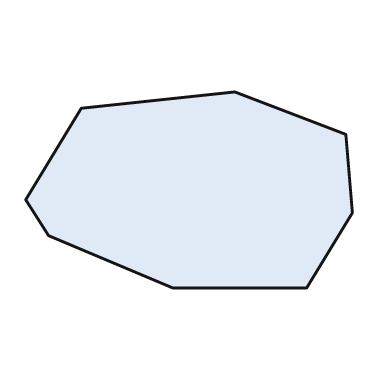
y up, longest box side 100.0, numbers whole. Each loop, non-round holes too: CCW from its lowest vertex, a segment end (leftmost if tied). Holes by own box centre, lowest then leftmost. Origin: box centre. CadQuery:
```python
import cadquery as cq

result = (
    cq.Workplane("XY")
    .moveTo(-5.0, -30.0)
    .lineTo(36.0, -30.0)
    .lineTo(50.0, -7.0)
    .lineTo(48.0, 17.0)
    .lineTo(14.0, 30.0)
    .lineTo(-33.0, 25.0)
    .lineTo(-50.0, -3.0)
    .lineTo(-43.0, -14.0)
    .close()
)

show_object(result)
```